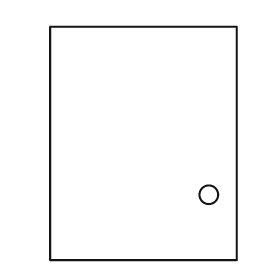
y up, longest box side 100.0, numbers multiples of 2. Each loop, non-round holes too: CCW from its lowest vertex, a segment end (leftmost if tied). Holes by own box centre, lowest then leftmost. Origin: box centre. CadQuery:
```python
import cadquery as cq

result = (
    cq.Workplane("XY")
    .moveTo(-40.0, -50.0)
    .lineTo(40.0, -50.0)
    .lineTo(40.0, 50.0)
    .lineTo(-40.0, 50.0)
    .close()
    .moveTo(28.0, -22.0)
    .circle(4.0)
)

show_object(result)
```